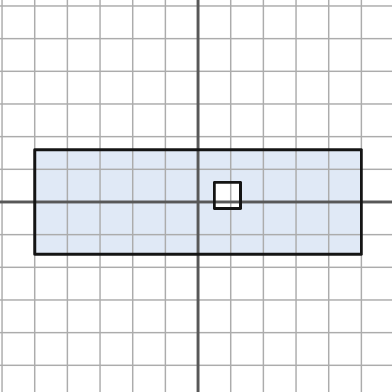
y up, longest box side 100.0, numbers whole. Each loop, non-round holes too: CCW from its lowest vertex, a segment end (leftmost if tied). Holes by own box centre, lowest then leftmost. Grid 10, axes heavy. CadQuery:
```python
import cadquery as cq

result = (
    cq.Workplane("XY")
    .moveTo(-50.0, -16.0)
    .lineTo(50.0, -16.0)
    .lineTo(50.0, 16.0)
    .lineTo(-50.0, 16.0)
    .close()
    .moveTo(5.0, -2.0)
    .lineTo(13.0, -2.0)
    .lineTo(13.0, 6.0)
    .lineTo(5.0, 6.0)
    .close()
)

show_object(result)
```